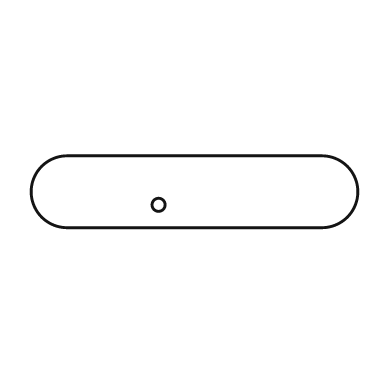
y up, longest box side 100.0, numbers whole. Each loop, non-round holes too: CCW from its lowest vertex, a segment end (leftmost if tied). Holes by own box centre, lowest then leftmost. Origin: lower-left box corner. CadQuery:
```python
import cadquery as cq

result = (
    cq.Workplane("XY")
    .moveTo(11.0, 0.0)
    .lineTo(89.0, 0.0)
    .threePointArc((100.0, 11.0), (89.0, 22.0))
    .lineTo(11.0, 22.0)
    .threePointArc((0.0, 11.0), (11.0, 0.0))
    .close()
    .moveTo(39.0, 7.0)
    .circle(2.0)
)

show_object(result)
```